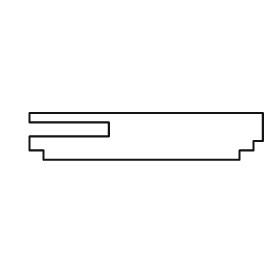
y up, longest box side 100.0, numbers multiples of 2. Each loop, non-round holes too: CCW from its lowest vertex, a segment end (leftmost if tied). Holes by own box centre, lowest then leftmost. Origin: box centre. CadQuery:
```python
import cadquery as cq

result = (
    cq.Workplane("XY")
    .moveTo(-44.0, -10.0)
    .lineTo(40.0, -10.0)
    .lineTo(40.0, -6.0)
    .lineTo(46.0, -6.0)
    .lineTo(46.0, -2.0)
    .lineTo(50.0, -2.0)
    .lineTo(50.0, 10.0)
    .lineTo(-50.0, 10.0)
    .lineTo(-50.0, 6.0)
    .lineTo(-16.0, 6.0)
    .lineTo(-16.0, 0.0)
    .lineTo(-50.0, 0.0)
    .lineTo(-50.0, -6.0)
    .lineTo(-44.0, -6.0)
    .close()
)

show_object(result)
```